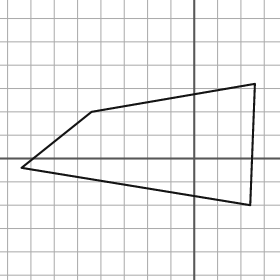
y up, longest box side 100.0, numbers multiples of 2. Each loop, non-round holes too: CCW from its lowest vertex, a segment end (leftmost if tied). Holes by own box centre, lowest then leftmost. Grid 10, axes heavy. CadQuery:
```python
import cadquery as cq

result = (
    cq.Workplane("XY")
    .moveTo(24.0, -20.0)
    .lineTo(26.0, 32.0)
    .lineTo(-44.0, 20.0)
    .lineTo(-74.0, -4.0)
    .close()
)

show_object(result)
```